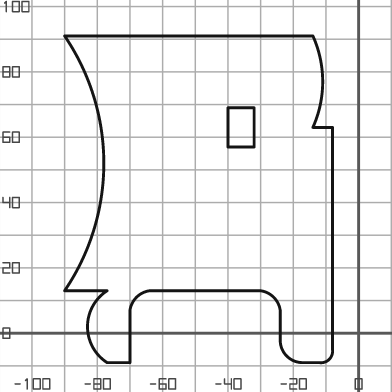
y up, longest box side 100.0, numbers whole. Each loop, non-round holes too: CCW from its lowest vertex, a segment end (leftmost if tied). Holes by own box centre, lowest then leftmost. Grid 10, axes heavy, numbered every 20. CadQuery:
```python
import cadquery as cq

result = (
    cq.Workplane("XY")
    .moveTo(-77.0, -9.0)
    .lineTo(-70.0, -9.0)
    .lineTo(-70.0, 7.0)
    .threePointArc((-68.0, 11.0), (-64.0, 13.0))
    .lineTo(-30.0, 13.0)
    .threePointArc((-26.0, 11.0), (-24.0, 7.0))
    .lineTo(-24.0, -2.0)
    .threePointArc((-22.0, -7.0), (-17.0, -9.0))
    .lineTo(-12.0, -9.0)
    .threePointArc((-9.0, -8.0), (-8.0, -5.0))
    .lineTo(-8.0, 63.0)
    .lineTo(-14.0, 63.0)
    .threePointArc((-11.0, 77.0), (-14.0, 91.0))
    .lineTo(-90.0, 91.0)
    .threePointArc((-78.0, 52.0), (-90.0, 13.0))
    .lineTo(-77.0, 13.0)
    .threePointArc((-83.0, 2.0), (-77.0, -9.0))
    .close()
    .moveTo(-40.0, 57.0)
    .lineTo(-32.0, 57.0)
    .lineTo(-32.0, 69.0)
    .lineTo(-40.0, 69.0)
    .close()
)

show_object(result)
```